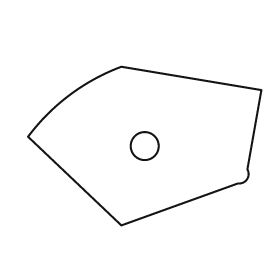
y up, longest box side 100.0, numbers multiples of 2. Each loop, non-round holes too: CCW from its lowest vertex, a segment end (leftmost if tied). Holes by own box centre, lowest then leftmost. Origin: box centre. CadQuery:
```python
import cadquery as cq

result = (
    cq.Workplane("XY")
    .moveTo(-10.0, -34.0)
    .lineTo(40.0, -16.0)
    .threePointArc((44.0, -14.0), (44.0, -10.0))
    .lineTo(50.0, 24.0)
    .lineTo(-10.0, 34.0)
    .threePointArc((-32.0, 22.0), (-50.0, 4.0))
    .close()
    .moveTo(0.0, 0.0)
    .circle(6.0)
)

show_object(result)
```